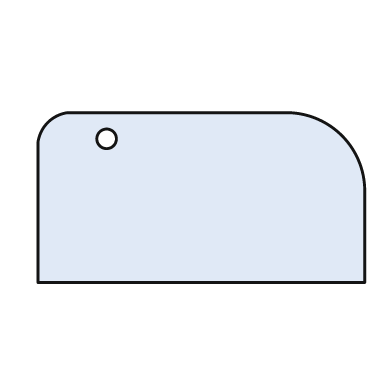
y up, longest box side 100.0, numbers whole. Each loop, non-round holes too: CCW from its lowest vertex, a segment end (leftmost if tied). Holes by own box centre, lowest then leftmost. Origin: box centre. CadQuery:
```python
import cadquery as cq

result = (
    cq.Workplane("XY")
    .moveTo(-50.0, -26.0)
    .lineTo(50.0, -26.0)
    .lineTo(50.0, 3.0)
    .threePointArc((43.0, 19.0), (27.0, 26.0))
    .lineTo(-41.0, 26.0)
    .threePointArc((-47.0, 23.0), (-50.0, 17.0))
    .close()
    .moveTo(-29.0, 18.0)
    .circle(3.0)
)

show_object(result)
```